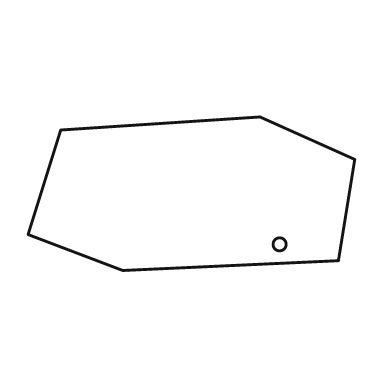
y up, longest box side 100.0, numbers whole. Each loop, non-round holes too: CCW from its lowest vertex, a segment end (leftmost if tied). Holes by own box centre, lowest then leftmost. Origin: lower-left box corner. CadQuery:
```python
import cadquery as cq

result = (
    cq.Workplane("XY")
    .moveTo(29.0, 0.0)
    .lineTo(95.0, 3.0)
    .lineTo(100.0, 34.0)
    .lineTo(71.0, 47.0)
    .lineTo(10.0, 43.0)
    .lineTo(0.0, 11.0)
    .close()
    .moveTo(77.0, 8.0)
    .circle(2.0)
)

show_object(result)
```